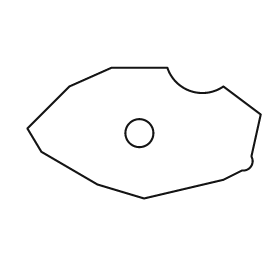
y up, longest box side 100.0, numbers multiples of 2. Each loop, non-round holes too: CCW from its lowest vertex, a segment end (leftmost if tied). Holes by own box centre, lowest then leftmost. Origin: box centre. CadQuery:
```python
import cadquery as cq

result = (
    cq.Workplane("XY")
    .moveTo(0.0, -28.0)
    .lineTo(34.0, -20.0)
    .lineTo(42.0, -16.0)
    .threePointArc((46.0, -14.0), (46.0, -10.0))
    .lineTo(50.0, 8.0)
    .lineTo(34.0, 20.0)
    .threePointArc((20.0, 18.0), (10.0, 28.0))
    .lineTo(-14.0, 28.0)
    .lineTo(-32.0, 20.0)
    .lineTo(-50.0, 2.0)
    .lineTo(-44.0, -8.0)
    .lineTo(-20.0, -22.0)
    .close()
    .moveTo(-2.0, 0.0)
    .circle(6.0)
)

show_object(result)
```